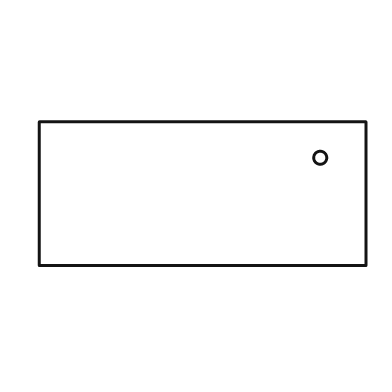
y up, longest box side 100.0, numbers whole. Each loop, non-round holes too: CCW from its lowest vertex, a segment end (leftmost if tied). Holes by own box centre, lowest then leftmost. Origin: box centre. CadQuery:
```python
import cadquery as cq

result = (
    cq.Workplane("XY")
    .moveTo(-50.0, -22.0)
    .lineTo(50.0, -22.0)
    .lineTo(50.0, 22.0)
    .lineTo(-50.0, 22.0)
    .close()
    .moveTo(36.0, 11.0)
    .circle(2.0)
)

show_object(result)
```